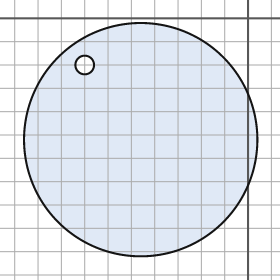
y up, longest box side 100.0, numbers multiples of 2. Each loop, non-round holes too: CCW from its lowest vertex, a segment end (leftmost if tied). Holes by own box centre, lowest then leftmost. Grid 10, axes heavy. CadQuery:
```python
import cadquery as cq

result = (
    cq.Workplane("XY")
    .moveTo(-46.0, -52.0)
    .circle(50.0)
    .moveTo(-70.0, -20.0)
    .circle(4.0)
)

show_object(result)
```